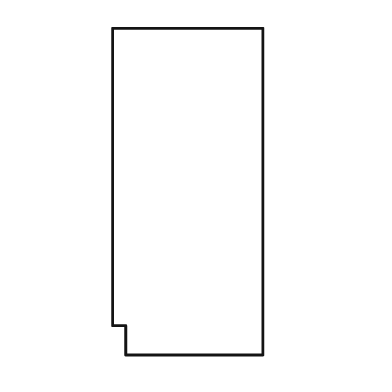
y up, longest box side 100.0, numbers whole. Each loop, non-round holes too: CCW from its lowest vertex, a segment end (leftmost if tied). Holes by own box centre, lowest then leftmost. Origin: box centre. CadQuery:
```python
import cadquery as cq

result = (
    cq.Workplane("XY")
    .moveTo(-19.0, -50.0)
    .lineTo(23.0, -50.0)
    .lineTo(23.0, 50.0)
    .lineTo(-23.0, 50.0)
    .lineTo(-23.0, -41.0)
    .lineTo(-19.0, -41.0)
    .close()
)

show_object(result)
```